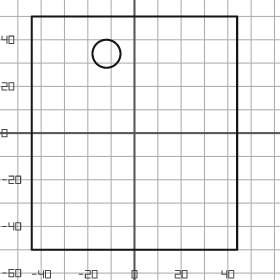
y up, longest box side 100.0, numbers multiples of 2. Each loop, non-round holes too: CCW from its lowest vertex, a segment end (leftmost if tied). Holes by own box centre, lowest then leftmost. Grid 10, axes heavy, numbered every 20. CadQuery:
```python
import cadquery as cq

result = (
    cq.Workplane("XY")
    .moveTo(-44.0, -50.0)
    .lineTo(44.0, -50.0)
    .lineTo(44.0, 50.0)
    .lineTo(-44.0, 50.0)
    .close()
    .moveTo(-12.0, 34.0)
    .circle(6.0)
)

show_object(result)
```